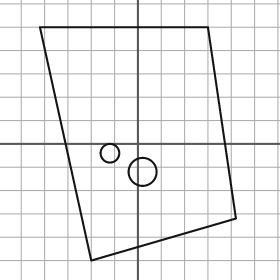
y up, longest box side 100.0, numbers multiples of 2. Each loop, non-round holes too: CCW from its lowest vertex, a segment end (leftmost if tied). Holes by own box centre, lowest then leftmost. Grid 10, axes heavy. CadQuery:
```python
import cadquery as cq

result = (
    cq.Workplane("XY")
    .moveTo(-20.0, -50.0)
    .lineTo(42.0, -32.0)
    .lineTo(30.0, 50.0)
    .lineTo(-42.0, 50.0)
    .close()
    .moveTo(2.0, -12.0)
    .circle(6.0)
    .moveTo(-12.0, -4.0)
    .circle(4.0)
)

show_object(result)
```